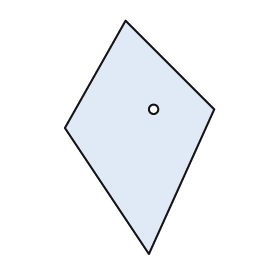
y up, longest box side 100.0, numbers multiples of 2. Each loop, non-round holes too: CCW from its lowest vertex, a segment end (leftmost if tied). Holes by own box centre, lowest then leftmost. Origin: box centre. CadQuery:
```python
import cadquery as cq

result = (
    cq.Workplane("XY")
    .moveTo(4.0, -50.0)
    .lineTo(32.0, 12.0)
    .lineTo(-6.0, 50.0)
    .lineTo(-32.0, 4.0)
    .close()
    .moveTo(6.0, 12.0)
    .circle(2.0)
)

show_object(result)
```